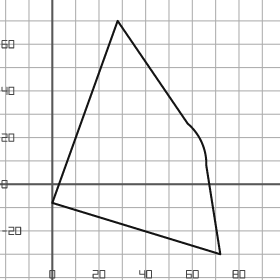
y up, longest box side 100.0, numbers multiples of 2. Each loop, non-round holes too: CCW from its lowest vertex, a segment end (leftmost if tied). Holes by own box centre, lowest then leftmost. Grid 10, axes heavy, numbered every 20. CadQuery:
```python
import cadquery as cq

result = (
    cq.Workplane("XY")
    .moveTo(72.0, -30.0)
    .lineTo(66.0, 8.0)
    .threePointArc((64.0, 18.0), (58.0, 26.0))
    .lineTo(28.0, 70.0)
    .lineTo(0.0, -8.0)
    .close()
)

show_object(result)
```